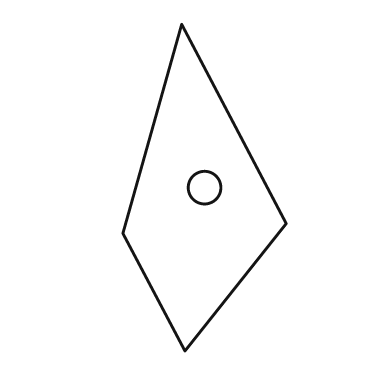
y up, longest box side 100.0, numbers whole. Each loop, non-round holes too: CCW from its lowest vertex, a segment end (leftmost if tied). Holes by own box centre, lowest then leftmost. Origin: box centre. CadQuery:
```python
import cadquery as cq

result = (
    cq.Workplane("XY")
    .moveTo(-6.0, -50.0)
    .lineTo(25.0, -11.0)
    .lineTo(-7.0, 50.0)
    .lineTo(-25.0, -14.0)
    .close()
    .moveTo(0.0, 0.0)
    .circle(5.0)
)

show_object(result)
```